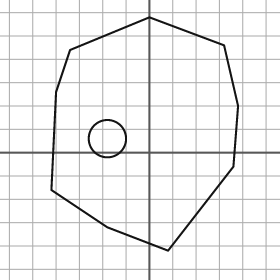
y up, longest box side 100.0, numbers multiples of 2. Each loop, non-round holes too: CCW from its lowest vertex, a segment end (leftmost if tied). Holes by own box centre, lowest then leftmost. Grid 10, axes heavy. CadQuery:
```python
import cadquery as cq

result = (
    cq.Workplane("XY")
    .moveTo(8.0, -42.0)
    .lineTo(36.0, -6.0)
    .lineTo(38.0, 20.0)
    .lineTo(32.0, 46.0)
    .lineTo(0.0, 58.0)
    .lineTo(-34.0, 44.0)
    .lineTo(-40.0, 26.0)
    .lineTo(-42.0, -16.0)
    .lineTo(-18.0, -32.0)
    .close()
    .moveTo(-18.0, 6.0)
    .circle(8.0)
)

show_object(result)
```